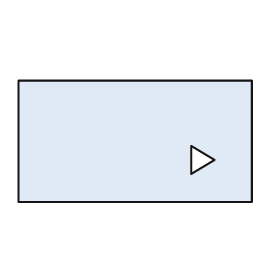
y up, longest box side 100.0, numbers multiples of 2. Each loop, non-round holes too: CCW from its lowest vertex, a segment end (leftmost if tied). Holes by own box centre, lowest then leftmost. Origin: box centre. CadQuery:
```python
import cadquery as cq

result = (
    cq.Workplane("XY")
    .moveTo(-50.0, -26.0)
    .lineTo(50.0, -26.0)
    .lineTo(50.0, 26.0)
    .lineTo(-50.0, 26.0)
    .close()
    .moveTo(24.0, -14.0)
    .lineTo(34.0, -8.0)
    .lineTo(24.0, -2.0)
    .close()
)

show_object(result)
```